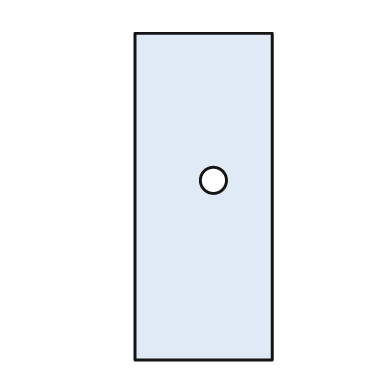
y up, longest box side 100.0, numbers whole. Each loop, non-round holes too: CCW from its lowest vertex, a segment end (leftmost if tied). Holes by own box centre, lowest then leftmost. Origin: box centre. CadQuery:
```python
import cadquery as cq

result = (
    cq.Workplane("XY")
    .moveTo(-21.0, -50.0)
    .lineTo(21.0, -50.0)
    .lineTo(21.0, 50.0)
    .lineTo(-21.0, 50.0)
    .close()
    .moveTo(3.0, 5.0)
    .circle(4.0)
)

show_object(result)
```